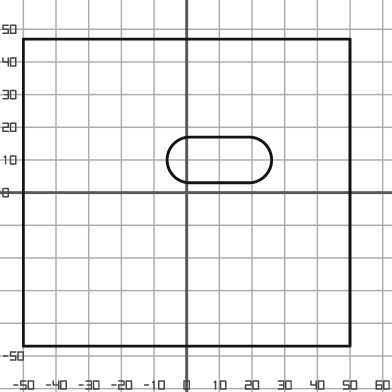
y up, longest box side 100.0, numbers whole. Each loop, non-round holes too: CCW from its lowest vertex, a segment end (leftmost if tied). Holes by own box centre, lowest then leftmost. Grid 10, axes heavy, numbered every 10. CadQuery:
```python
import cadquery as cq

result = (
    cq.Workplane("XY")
    .moveTo(-50.0, -47.0)
    .lineTo(50.0, -47.0)
    .lineTo(50.0, 47.0)
    .lineTo(-50.0, 47.0)
    .close()
    .moveTo(1.0, 3.0)
    .lineTo(19.0, 3.0)
    .threePointArc((26.0, 10.0), (19.0, 17.0))
    .lineTo(1.0, 17.0)
    .threePointArc((-6.0, 10.0), (1.0, 3.0))
    .close()
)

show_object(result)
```